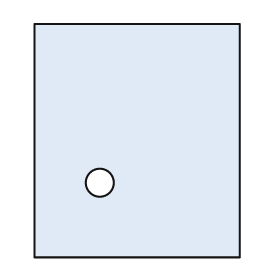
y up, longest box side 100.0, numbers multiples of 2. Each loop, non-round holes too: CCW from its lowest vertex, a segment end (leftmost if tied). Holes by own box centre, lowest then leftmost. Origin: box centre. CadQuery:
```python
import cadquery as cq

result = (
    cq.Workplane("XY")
    .moveTo(-44.0, -50.0)
    .lineTo(44.0, -50.0)
    .lineTo(44.0, 50.0)
    .lineTo(-44.0, 50.0)
    .close()
    .moveTo(-16.0, -18.0)
    .circle(6.0)
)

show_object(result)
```